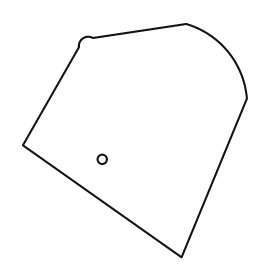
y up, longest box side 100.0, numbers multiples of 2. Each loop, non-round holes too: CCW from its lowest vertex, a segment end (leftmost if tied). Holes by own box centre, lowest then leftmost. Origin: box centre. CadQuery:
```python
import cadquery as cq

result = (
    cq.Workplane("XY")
    .moveTo(20.0, -50.0)
    .lineTo(48.0, 18.0)
    .threePointArc((40.0, 38.0), (22.0, 50.0))
    .lineTo(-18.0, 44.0)
    .threePointArc((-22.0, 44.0), (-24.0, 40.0))
    .lineTo(-48.0, -2.0)
    .close()
    .moveTo(-14.0, -8.0)
    .circle(2.0)
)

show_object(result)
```